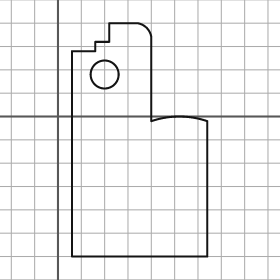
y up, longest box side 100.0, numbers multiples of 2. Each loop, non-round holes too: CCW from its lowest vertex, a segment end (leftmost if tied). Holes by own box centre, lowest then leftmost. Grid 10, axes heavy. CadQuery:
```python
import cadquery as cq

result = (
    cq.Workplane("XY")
    .moveTo(6.0, -60.0)
    .lineTo(64.0, -60.0)
    .lineTo(64.0, -2.0)
    .threePointArc((52.0, 0.0), (40.0, -2.0))
    .lineTo(40.0, 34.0)
    .threePointArc((38.0, 38.0), (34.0, 40.0))
    .lineTo(22.0, 40.0)
    .lineTo(22.0, 32.0)
    .lineTo(16.0, 32.0)
    .lineTo(16.0, 28.0)
    .lineTo(6.0, 28.0)
    .close()
    .moveTo(20.0, 18.0)
    .circle(6.0)
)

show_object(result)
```